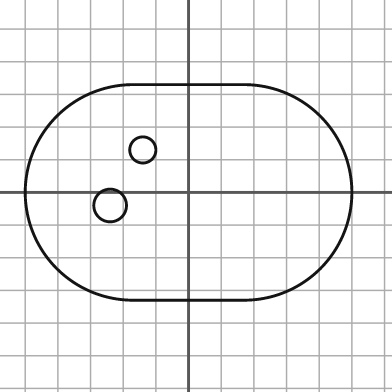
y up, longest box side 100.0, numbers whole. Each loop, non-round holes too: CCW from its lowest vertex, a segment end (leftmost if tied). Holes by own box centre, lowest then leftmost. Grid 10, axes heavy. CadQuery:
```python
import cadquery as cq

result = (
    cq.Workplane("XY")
    .moveTo(-17.0, -33.0)
    .lineTo(17.0, -33.0)
    .threePointArc((50.0, 0.0), (17.0, 33.0))
    .lineTo(-17.0, 33.0)
    .threePointArc((-50.0, 0.0), (-17.0, -33.0))
    .close()
    .moveTo(-24.0, -4.0)
    .circle(5.0)
    .moveTo(-14.0, 13.0)
    .circle(4.0)
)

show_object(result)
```